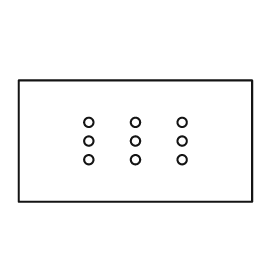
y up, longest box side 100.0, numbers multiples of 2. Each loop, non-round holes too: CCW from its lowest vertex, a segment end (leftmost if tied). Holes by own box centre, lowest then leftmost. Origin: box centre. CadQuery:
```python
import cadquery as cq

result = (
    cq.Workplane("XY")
    .moveTo(-50.0, -26.0)
    .lineTo(50.0, -26.0)
    .lineTo(50.0, 26.0)
    .lineTo(-50.0, 26.0)
    .close()
    .moveTo(-20.0, -8.0)
    .circle(2.0)
    .moveTo(0.0, -8.0)
    .circle(2.0)
    .moveTo(20.0, -8.0)
    .circle(2.0)
    .moveTo(-20.0, 0.0)
    .circle(2.0)
    .moveTo(0.0, 0.0)
    .circle(2.0)
    .moveTo(20.0, 0.0)
    .circle(2.0)
    .moveTo(-20.0, 8.0)
    .circle(2.0)
    .moveTo(0.0, 8.0)
    .circle(2.0)
    .moveTo(20.0, 8.0)
    .circle(2.0)
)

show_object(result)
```